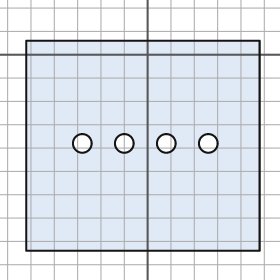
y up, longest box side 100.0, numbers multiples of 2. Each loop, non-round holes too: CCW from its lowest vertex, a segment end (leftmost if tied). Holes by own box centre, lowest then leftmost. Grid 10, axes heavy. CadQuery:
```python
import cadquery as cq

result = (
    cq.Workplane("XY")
    .moveTo(-52.0, -84.0)
    .lineTo(48.0, -84.0)
    .lineTo(48.0, 6.0)
    .lineTo(-52.0, 6.0)
    .close()
    .moveTo(-28.0, -38.0)
    .circle(4.0)
    .moveTo(-10.0, -38.0)
    .circle(4.0)
    .moveTo(8.0, -38.0)
    .circle(4.0)
    .moveTo(26.0, -38.0)
    .circle(4.0)
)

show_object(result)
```